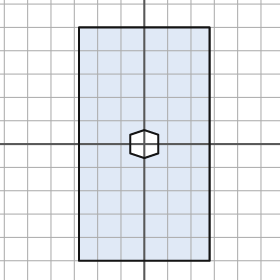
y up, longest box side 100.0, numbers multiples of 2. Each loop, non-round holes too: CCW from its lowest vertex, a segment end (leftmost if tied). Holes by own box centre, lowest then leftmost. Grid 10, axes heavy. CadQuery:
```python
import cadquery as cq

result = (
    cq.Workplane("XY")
    .moveTo(-28.0, -50.0)
    .lineTo(28.0, -50.0)
    .lineTo(28.0, 50.0)
    .lineTo(-28.0, 50.0)
    .close()
    .moveTo(0.0, -6.0)
    .lineTo(6.0, -4.0)
    .lineTo(6.0, 4.0)
    .lineTo(0.0, 6.0)
    .lineTo(-6.0, 4.0)
    .lineTo(-6.0, -4.0)
    .close()
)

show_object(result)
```